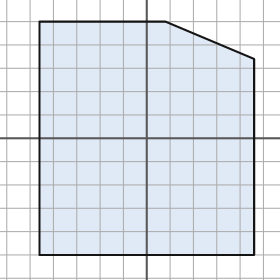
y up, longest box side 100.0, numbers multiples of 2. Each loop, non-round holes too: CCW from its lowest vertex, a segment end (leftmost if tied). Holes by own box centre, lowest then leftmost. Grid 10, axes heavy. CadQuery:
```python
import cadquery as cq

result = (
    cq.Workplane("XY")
    .moveTo(-46.0, -50.0)
    .lineTo(46.0, -50.0)
    .lineTo(46.0, 34.0)
    .lineTo(8.0, 50.0)
    .lineTo(-46.0, 50.0)
    .close()
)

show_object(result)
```